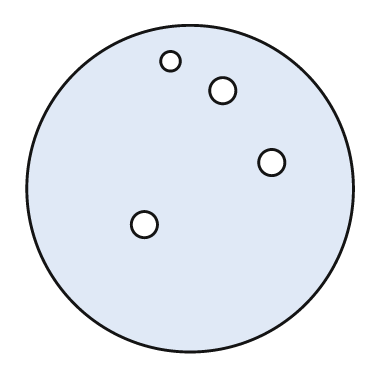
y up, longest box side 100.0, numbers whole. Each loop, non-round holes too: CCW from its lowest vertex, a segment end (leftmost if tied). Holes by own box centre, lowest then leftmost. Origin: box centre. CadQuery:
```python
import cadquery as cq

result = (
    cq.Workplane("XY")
    .moveTo(0.0, 0.0)
    .circle(50.0)
    .moveTo(-14.0, -11.0)
    .circle(4.0)
    .moveTo(25.0, 8.0)
    .circle(4.0)
    .moveTo(10.0, 30.0)
    .circle(4.0)
    .moveTo(-6.0, 39.0)
    .circle(3.0)
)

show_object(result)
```